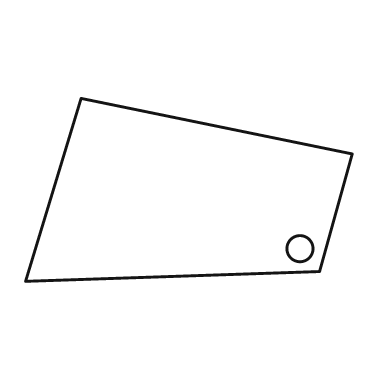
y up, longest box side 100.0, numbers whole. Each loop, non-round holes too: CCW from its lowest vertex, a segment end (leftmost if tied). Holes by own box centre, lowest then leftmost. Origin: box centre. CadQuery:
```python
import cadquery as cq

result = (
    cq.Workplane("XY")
    .moveTo(-50.0, -28.0)
    .lineTo(40.0, -25.0)
    .lineTo(50.0, 11.0)
    .lineTo(-33.0, 28.0)
    .close()
    .moveTo(34.0, -18.0)
    .circle(4.0)
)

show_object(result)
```